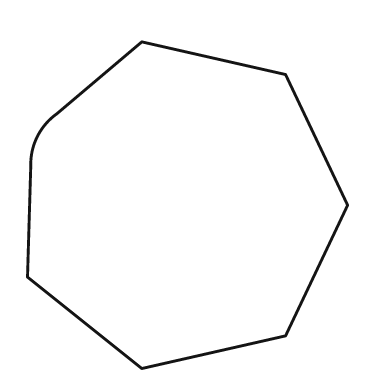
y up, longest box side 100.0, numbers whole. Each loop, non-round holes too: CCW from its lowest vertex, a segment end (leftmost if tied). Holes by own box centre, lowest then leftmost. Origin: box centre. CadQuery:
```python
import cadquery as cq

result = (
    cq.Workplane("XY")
    .moveTo(-14.0, -50.0)
    .lineTo(30.0, -40.0)
    .lineTo(49.0, 0.0)
    .lineTo(30.0, 40.0)
    .lineTo(-14.0, 50.0)
    .lineTo(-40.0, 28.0)
    .threePointArc((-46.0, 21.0), (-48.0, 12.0))
    .lineTo(-49.0, -22.0)
    .close()
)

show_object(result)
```